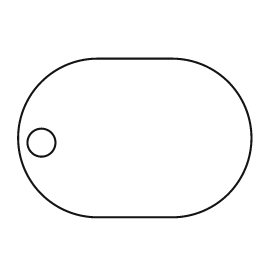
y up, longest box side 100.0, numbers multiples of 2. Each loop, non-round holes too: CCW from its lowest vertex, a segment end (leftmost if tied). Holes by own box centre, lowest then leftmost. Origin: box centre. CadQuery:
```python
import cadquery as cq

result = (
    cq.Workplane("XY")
    .moveTo(-16.0, -34.0)
    .lineTo(16.0, -34.0)
    .threePointArc((50.0, 0.0), (16.0, 34.0))
    .lineTo(-16.0, 34.0)
    .threePointArc((-50.0, 0.0), (-16.0, -34.0))
    .close()
    .moveTo(-40.0, -2.0)
    .circle(6.0)
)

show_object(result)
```